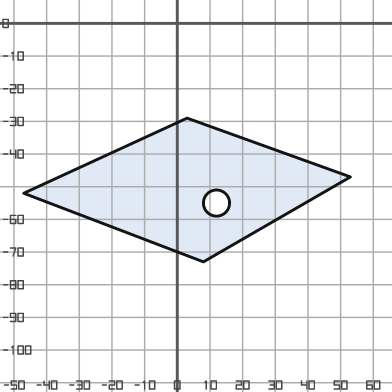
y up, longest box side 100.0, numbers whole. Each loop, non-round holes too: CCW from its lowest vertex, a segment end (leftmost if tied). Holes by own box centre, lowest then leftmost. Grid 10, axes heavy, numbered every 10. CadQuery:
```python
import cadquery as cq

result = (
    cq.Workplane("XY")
    .moveTo(8.0, -73.0)
    .lineTo(53.0, -47.0)
    .lineTo(3.0, -29.0)
    .lineTo(-47.0, -52.0)
    .close()
    .moveTo(12.0, -55.0)
    .circle(4.0)
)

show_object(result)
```